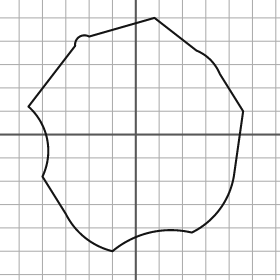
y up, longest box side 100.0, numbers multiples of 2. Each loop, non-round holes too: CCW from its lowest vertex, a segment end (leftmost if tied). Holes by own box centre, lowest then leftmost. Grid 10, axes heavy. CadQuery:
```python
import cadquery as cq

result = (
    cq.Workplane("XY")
    .moveTo(-10.0, -50.0)
    .threePointArc((6.0, -42.0), (24.0, -42.0))
    .threePointArc((36.0, -32.0), (42.0, -18.0))
    .lineTo(46.0, 10.0)
    .lineTo(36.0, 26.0)
    .threePointArc((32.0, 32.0), (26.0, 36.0))
    .lineTo(8.0, 50.0)
    .lineTo(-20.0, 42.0)
    .threePointArc((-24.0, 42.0), (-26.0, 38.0))
    .lineTo(-46.0, 12.0)
    .threePointArc((-38.0, -2.0), (-40.0, -18.0))
    .lineTo(-30.0, -34.0)
    .threePointArc((-22.0, -44.0), (-10.0, -50.0))
    .close()
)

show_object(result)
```